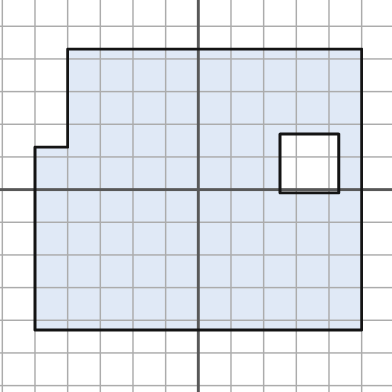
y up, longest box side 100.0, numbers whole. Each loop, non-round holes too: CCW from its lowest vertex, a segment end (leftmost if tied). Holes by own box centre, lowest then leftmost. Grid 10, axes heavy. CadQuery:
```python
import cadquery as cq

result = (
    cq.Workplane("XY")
    .moveTo(-50.0, -43.0)
    .lineTo(50.0, -43.0)
    .lineTo(50.0, 43.0)
    .lineTo(-40.0, 43.0)
    .lineTo(-40.0, 13.0)
    .lineTo(-50.0, 13.0)
    .close()
    .moveTo(25.0, -1.0)
    .lineTo(43.0, -1.0)
    .lineTo(43.0, 17.0)
    .lineTo(25.0, 17.0)
    .close()
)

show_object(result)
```